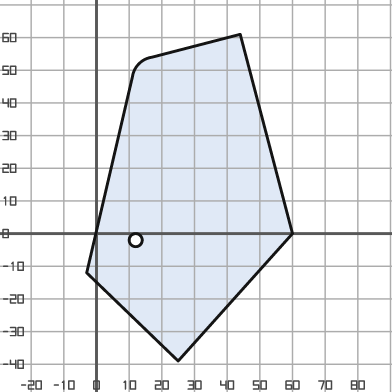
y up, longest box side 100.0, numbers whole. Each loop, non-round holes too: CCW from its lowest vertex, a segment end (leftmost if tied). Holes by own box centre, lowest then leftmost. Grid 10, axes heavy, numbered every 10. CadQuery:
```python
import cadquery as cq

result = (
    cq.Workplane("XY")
    .moveTo(25.0, -39.0)
    .lineTo(60.0, 0.0)
    .lineTo(44.0, 61.0)
    .lineTo(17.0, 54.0)
    .threePointArc((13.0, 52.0), (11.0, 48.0))
    .lineTo(-3.0, -12.0)
    .close()
    .moveTo(12.0, -2.0)
    .circle(2.0)
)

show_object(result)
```